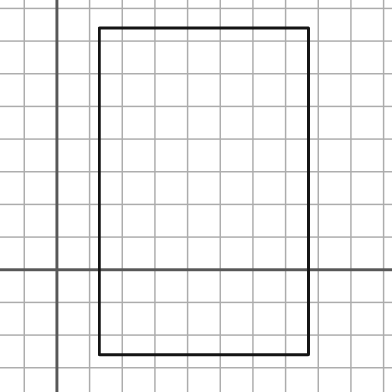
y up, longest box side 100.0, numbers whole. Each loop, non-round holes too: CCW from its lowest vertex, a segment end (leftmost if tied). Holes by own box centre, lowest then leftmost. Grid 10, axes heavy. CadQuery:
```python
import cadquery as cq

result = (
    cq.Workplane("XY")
    .moveTo(13.0, -26.0)
    .lineTo(77.0, -26.0)
    .lineTo(77.0, 74.0)
    .lineTo(13.0, 74.0)
    .close()
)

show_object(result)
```